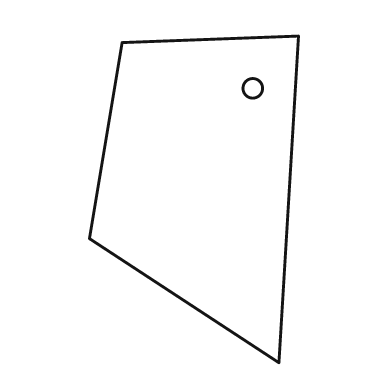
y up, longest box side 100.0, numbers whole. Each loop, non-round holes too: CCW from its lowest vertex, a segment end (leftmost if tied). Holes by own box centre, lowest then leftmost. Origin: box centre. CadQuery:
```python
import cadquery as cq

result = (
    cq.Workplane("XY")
    .moveTo(26.0, -50.0)
    .lineTo(32.0, 50.0)
    .lineTo(-22.0, 48.0)
    .lineTo(-32.0, -12.0)
    .close()
    .moveTo(18.0, 34.0)
    .circle(3.0)
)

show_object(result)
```